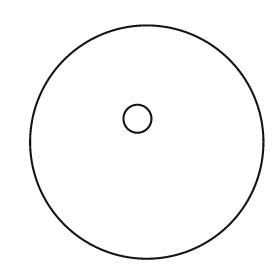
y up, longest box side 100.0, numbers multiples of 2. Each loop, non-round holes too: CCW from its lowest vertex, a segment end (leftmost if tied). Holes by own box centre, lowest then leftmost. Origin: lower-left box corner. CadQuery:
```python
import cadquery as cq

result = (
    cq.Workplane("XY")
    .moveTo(50.0, 50.0)
    .circle(50.0)
    .moveTo(46.0, 60.0)
    .circle(6.0)
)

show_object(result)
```